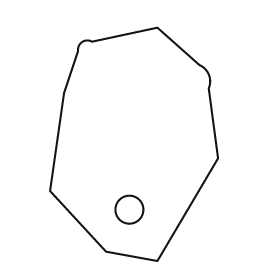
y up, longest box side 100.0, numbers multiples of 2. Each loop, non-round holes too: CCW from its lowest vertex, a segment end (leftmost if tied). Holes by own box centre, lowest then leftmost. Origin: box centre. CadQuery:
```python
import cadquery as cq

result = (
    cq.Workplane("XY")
    .moveTo(10.0, -50.0)
    .lineTo(36.0, -6.0)
    .lineTo(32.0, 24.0)
    .threePointArc((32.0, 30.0), (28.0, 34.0))
    .lineTo(10.0, 50.0)
    .lineTo(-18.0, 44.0)
    .threePointArc((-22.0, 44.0), (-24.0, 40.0))
    .lineTo(-30.0, 22.0)
    .lineTo(-36.0, -20.0)
    .lineTo(-12.0, -46.0)
    .close()
    .moveTo(-2.0, -28.0)
    .circle(6.0)
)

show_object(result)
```